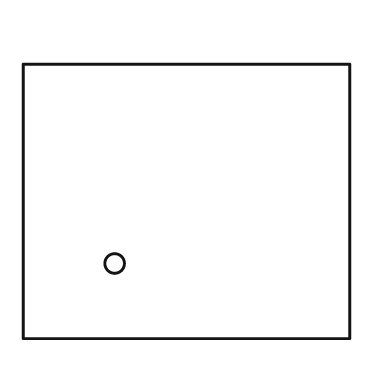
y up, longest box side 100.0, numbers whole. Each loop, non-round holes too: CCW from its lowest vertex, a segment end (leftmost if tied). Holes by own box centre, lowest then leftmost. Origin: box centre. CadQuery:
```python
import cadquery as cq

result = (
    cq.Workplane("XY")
    .moveTo(-50.0, -42.0)
    .lineTo(50.0, -42.0)
    .lineTo(50.0, 42.0)
    .lineTo(-50.0, 42.0)
    .close()
    .moveTo(-22.0, -19.0)
    .circle(3.0)
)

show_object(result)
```